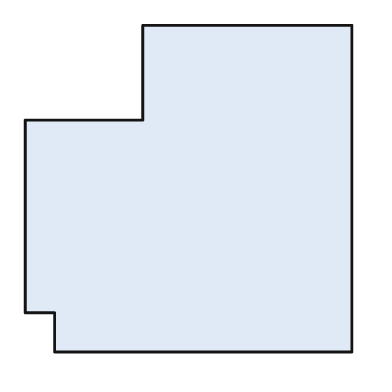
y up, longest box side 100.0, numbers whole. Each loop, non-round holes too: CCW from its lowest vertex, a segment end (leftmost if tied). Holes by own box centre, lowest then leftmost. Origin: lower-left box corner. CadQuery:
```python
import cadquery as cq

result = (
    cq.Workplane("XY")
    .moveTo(9.0, 0.0)
    .lineTo(100.0, 0.0)
    .lineTo(100.0, 100.0)
    .lineTo(36.0, 100.0)
    .lineTo(36.0, 71.0)
    .lineTo(0.0, 71.0)
    .lineTo(0.0, 12.0)
    .lineTo(9.0, 12.0)
    .close()
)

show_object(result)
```